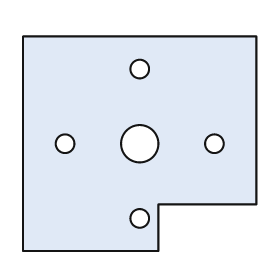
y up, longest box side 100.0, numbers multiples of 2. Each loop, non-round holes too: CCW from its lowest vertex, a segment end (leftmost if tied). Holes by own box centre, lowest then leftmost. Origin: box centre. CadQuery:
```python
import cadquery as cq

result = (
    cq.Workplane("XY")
    .moveTo(-50.0, -46.0)
    .lineTo(8.0, -46.0)
    .lineTo(8.0, -26.0)
    .lineTo(50.0, -26.0)
    .lineTo(50.0, 46.0)
    .lineTo(-50.0, 46.0)
    .close()
    .moveTo(0.0, -32.0)
    .circle(4.0)
    .moveTo(-32.0, 0.0)
    .circle(4.0)
    .moveTo(0.0, 0.0)
    .circle(8.0)
    .moveTo(32.0, 0.0)
    .circle(4.0)
    .moveTo(0.0, 32.0)
    .circle(4.0)
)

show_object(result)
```